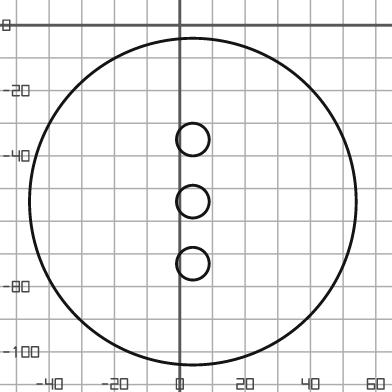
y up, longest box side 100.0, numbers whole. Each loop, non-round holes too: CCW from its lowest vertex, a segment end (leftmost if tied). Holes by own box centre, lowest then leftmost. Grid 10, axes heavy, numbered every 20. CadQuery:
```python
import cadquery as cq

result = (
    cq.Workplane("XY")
    .moveTo(4.0, -54.0)
    .circle(50.0)
    .moveTo(4.0, -73.0)
    .circle(5.0)
    .moveTo(4.0, -54.0)
    .circle(5.0)
    .moveTo(4.0, -35.0)
    .circle(5.0)
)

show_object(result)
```